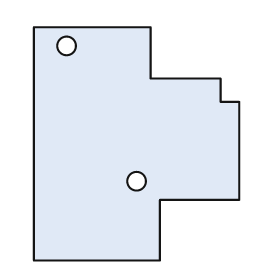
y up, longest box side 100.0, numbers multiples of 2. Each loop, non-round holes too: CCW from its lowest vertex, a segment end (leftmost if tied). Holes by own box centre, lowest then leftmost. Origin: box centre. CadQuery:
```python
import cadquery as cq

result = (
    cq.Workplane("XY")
    .moveTo(-44.0, -50.0)
    .lineTo(10.0, -50.0)
    .lineTo(10.0, -24.0)
    .lineTo(44.0, -24.0)
    .lineTo(44.0, 18.0)
    .lineTo(36.0, 18.0)
    .lineTo(36.0, 28.0)
    .lineTo(6.0, 28.0)
    .lineTo(6.0, 50.0)
    .lineTo(-44.0, 50.0)
    .close()
    .moveTo(0.0, -16.0)
    .circle(4.0)
    .moveTo(-30.0, 42.0)
    .circle(4.0)
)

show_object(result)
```